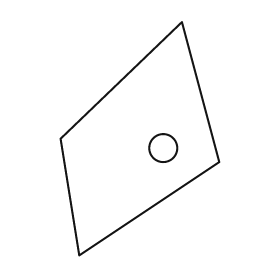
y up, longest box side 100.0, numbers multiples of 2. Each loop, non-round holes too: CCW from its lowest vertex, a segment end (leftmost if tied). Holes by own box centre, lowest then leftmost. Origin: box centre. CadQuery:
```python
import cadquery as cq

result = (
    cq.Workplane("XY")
    .moveTo(-26.0, -50.0)
    .lineTo(34.0, -10.0)
    .lineTo(18.0, 50.0)
    .lineTo(-34.0, 0.0)
    .close()
    .moveTo(10.0, -4.0)
    .circle(6.0)
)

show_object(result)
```